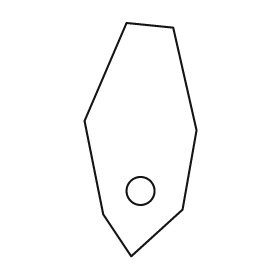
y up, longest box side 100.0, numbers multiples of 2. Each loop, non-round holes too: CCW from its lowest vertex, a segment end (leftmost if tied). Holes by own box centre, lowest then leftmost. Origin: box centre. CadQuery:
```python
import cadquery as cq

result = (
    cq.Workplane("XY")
    .moveTo(-4.0, -50.0)
    .lineTo(18.0, -30.0)
    .lineTo(24.0, 4.0)
    .lineTo(14.0, 48.0)
    .lineTo(-6.0, 50.0)
    .lineTo(-24.0, 8.0)
    .lineTo(-16.0, -32.0)
    .close()
    .moveTo(0.0, -22.0)
    .circle(6.0)
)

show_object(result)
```